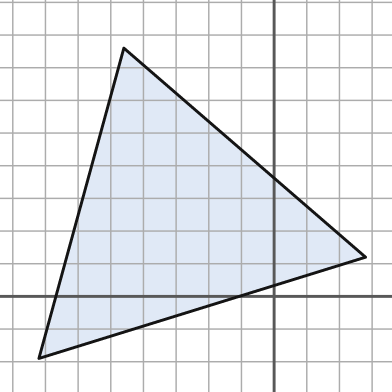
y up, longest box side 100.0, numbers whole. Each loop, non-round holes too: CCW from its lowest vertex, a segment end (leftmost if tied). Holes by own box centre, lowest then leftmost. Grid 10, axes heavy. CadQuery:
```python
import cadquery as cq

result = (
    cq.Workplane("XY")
    .moveTo(-72.0, -19.0)
    .lineTo(28.0, 12.0)
    .lineTo(-46.0, 76.0)
    .close()
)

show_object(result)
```